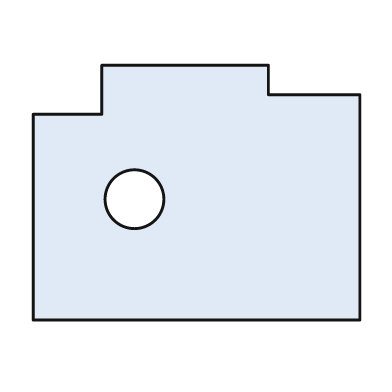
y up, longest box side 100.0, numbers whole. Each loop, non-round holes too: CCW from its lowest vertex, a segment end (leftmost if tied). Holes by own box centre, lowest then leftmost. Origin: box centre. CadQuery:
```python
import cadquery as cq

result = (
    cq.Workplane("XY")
    .moveTo(-50.0, -39.0)
    .lineTo(50.0, -39.0)
    .lineTo(50.0, 30.0)
    .lineTo(22.0, 30.0)
    .lineTo(22.0, 39.0)
    .lineTo(-29.0, 39.0)
    .lineTo(-29.0, 24.0)
    .lineTo(-50.0, 24.0)
    .close()
    .moveTo(-19.0, -2.0)
    .circle(9.0)
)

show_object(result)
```